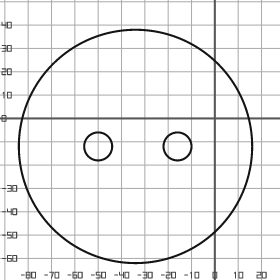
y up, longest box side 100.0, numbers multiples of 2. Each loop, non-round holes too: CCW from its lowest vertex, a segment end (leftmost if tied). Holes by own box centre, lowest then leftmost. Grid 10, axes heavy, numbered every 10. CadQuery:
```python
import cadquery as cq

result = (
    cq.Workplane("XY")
    .moveTo(-34.0, -12.0)
    .circle(50.0)
    .moveTo(-50.0, -12.0)
    .circle(6.0)
    .moveTo(-16.0, -12.0)
    .circle(6.0)
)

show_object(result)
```